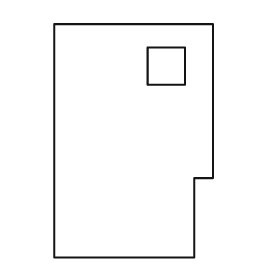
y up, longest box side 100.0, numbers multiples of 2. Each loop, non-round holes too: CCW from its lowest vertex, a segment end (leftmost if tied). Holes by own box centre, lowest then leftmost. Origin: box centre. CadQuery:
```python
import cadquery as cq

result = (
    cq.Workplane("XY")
    .moveTo(-34.0, -50.0)
    .lineTo(26.0, -50.0)
    .lineTo(26.0, -16.0)
    .lineTo(34.0, -16.0)
    .lineTo(34.0, 50.0)
    .lineTo(-34.0, 50.0)
    .close()
    .moveTo(6.0, 24.0)
    .lineTo(22.0, 24.0)
    .lineTo(22.0, 40.0)
    .lineTo(6.0, 40.0)
    .close()
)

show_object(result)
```